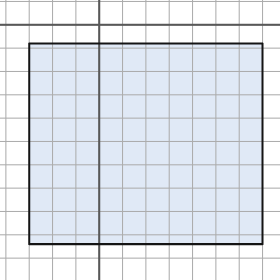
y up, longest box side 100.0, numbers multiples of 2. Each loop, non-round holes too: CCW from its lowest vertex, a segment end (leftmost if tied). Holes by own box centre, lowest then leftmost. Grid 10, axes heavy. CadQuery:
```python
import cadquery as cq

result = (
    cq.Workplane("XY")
    .moveTo(-30.0, -94.0)
    .lineTo(70.0, -94.0)
    .lineTo(70.0, -8.0)
    .lineTo(-30.0, -8.0)
    .close()
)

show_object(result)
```